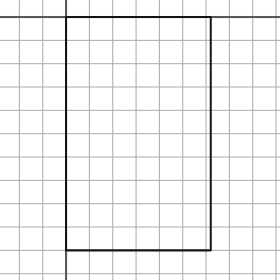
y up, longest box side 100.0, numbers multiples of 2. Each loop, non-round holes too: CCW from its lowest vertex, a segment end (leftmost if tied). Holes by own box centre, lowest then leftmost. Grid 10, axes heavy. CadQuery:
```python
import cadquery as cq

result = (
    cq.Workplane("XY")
    .moveTo(0.0, -100.0)
    .lineTo(62.0, -100.0)
    .lineTo(62.0, 0.0)
    .lineTo(0.0, 0.0)
    .close()
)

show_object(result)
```